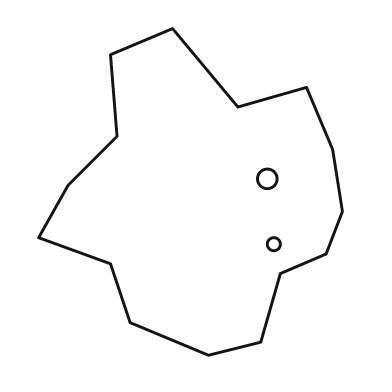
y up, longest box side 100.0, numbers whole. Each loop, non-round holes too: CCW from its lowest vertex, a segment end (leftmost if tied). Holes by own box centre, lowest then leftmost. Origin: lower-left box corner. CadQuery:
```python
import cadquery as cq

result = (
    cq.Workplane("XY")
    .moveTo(52.0, 0.0)
    .lineTo(68.0, 4.0)
    .lineTo(74.0, 25.0)
    .lineTo(88.0, 31.0)
    .lineTo(93.0, 44.0)
    .lineTo(90.0, 63.0)
    .lineTo(82.0, 82.0)
    .lineTo(61.0, 76.0)
    .lineTo(41.0, 100.0)
    .lineTo(22.0, 92.0)
    .lineTo(24.0, 67.0)
    .lineTo(9.0, 52.0)
    .lineTo(0.0, 36.0)
    .lineTo(22.0, 28.0)
    .lineTo(28.0, 10.0)
    .close()
    .moveTo(72.0, 34.0)
    .circle(2.0)
    .moveTo(70.0, 54.0)
    .circle(3.0)
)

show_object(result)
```